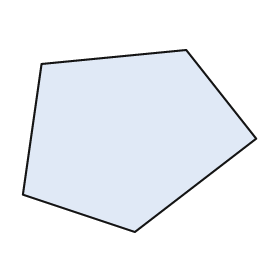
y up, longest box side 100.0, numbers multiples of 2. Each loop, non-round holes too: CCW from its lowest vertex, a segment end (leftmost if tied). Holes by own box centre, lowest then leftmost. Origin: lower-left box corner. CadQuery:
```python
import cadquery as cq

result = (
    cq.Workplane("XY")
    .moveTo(48.0, 0.0)
    .lineTo(100.0, 40.0)
    .lineTo(70.0, 78.0)
    .lineTo(8.0, 72.0)
    .lineTo(0.0, 16.0)
    .close()
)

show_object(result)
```